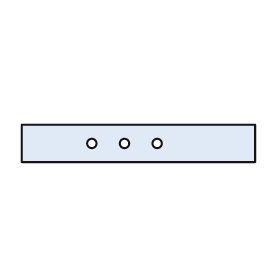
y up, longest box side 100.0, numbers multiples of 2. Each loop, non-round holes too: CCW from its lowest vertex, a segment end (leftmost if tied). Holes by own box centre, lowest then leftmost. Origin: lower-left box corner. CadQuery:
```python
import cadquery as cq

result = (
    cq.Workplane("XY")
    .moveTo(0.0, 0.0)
    .lineTo(100.0, 0.0)
    .lineTo(100.0, 16.0)
    .lineTo(0.0, 16.0)
    .close()
    .moveTo(30.0, 8.0)
    .circle(2.0)
    .moveTo(44.0, 8.0)
    .circle(2.0)
    .moveTo(58.0, 8.0)
    .circle(2.0)
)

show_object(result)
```